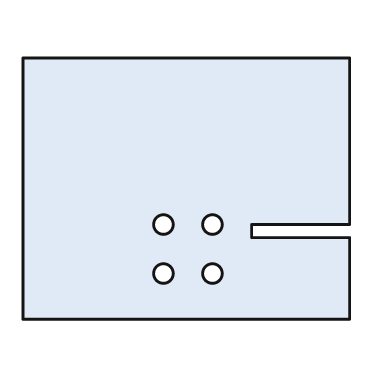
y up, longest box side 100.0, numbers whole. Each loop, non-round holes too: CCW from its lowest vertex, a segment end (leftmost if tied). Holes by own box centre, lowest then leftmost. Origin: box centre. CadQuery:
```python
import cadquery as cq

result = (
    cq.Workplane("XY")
    .moveTo(-50.0, -40.0)
    .lineTo(50.0, -40.0)
    .lineTo(50.0, -15.0)
    .lineTo(20.0, -15.0)
    .lineTo(20.0, -11.0)
    .lineTo(50.0, -11.0)
    .lineTo(50.0, 40.0)
    .lineTo(-50.0, 40.0)
    .close()
    .moveTo(-7.0, -26.0)
    .circle(3.0)
    .moveTo(8.0, -26.0)
    .circle(3.0)
    .moveTo(-7.0, -11.0)
    .circle(3.0)
    .moveTo(8.0, -11.0)
    .circle(3.0)
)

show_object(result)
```